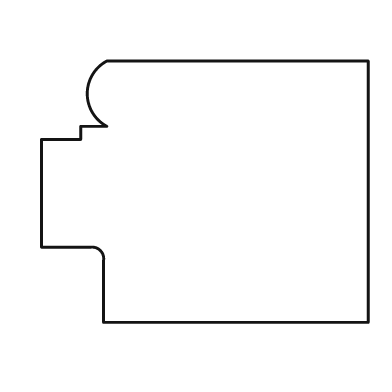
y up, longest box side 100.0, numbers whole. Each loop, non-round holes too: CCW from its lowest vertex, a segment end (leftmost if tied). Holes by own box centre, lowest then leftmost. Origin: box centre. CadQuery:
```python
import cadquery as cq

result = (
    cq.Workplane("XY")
    .moveTo(-31.0, -40.0)
    .lineTo(50.0, -40.0)
    .lineTo(50.0, 40.0)
    .lineTo(-30.0, 40.0)
    .threePointArc((-36.0, 30.0), (-30.0, 20.0))
    .lineTo(-38.0, 20.0)
    .lineTo(-38.0, 16.0)
    .lineTo(-50.0, 16.0)
    .lineTo(-50.0, -17.0)
    .lineTo(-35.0, -17.0)
    .threePointArc((-32.0, -18.0), (-31.0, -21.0))
    .close()
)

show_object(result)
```